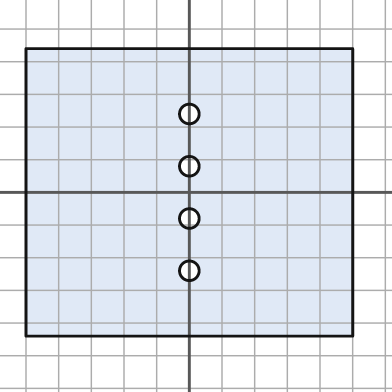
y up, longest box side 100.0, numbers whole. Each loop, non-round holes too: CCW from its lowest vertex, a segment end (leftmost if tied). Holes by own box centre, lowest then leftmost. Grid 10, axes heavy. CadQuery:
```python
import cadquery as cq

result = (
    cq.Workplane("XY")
    .moveTo(-50.0, -44.0)
    .lineTo(50.0, -44.0)
    .lineTo(50.0, 44.0)
    .lineTo(-50.0, 44.0)
    .close()
    .moveTo(0.0, -24.0)
    .circle(3.0)
    .moveTo(0.0, -8.0)
    .circle(3.0)
    .moveTo(0.0, 8.0)
    .circle(3.0)
    .moveTo(0.0, 24.0)
    .circle(3.0)
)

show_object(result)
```